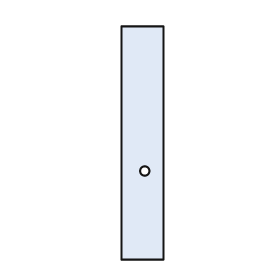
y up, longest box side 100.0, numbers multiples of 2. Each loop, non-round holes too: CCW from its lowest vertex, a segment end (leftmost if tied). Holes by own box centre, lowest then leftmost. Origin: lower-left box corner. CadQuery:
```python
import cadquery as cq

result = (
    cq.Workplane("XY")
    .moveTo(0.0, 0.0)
    .lineTo(18.0, 0.0)
    .lineTo(18.0, 100.0)
    .lineTo(0.0, 100.0)
    .close()
    .moveTo(10.0, 38.0)
    .circle(2.0)
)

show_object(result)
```